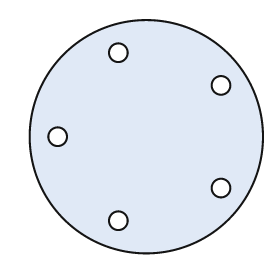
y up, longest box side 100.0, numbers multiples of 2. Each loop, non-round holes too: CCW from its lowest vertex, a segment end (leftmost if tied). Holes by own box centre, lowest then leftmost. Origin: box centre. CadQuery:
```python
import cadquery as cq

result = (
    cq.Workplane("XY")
    .moveTo(0.0, 0.0)
    .circle(50.0)
    .moveTo(-12.0, -36.0)
    .circle(4.0)
    .moveTo(32.0, -22.0)
    .circle(4.0)
    .moveTo(-38.0, 0.0)
    .circle(4.0)
    .moveTo(32.0, 22.0)
    .circle(4.0)
    .moveTo(-12.0, 36.0)
    .circle(4.0)
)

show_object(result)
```